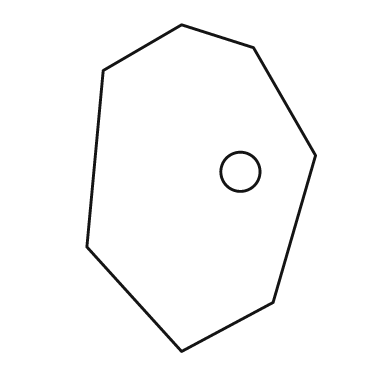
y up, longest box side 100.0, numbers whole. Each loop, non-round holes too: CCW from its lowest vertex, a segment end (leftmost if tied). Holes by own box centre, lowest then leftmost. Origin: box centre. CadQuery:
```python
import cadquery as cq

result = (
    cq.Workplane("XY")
    .moveTo(-6.0, -50.0)
    .lineTo(22.0, -35.0)
    .lineTo(35.0, 10.0)
    .lineTo(16.0, 43.0)
    .lineTo(-6.0, 50.0)
    .lineTo(-30.0, 36.0)
    .lineTo(-35.0, -18.0)
    .close()
    .moveTo(12.0, 5.0)
    .circle(6.0)
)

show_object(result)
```